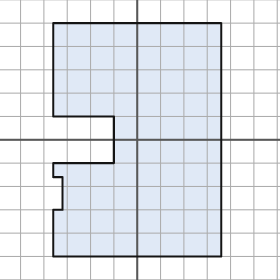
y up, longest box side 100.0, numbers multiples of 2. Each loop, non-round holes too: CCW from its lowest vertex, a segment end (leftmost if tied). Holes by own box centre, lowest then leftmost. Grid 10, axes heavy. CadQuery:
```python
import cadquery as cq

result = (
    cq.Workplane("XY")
    .moveTo(-36.0, -50.0)
    .lineTo(36.0, -50.0)
    .lineTo(36.0, 50.0)
    .lineTo(-36.0, 50.0)
    .lineTo(-36.0, 10.0)
    .lineTo(-10.0, 10.0)
    .lineTo(-10.0, -10.0)
    .lineTo(-36.0, -10.0)
    .lineTo(-36.0, -16.0)
    .lineTo(-32.0, -16.0)
    .lineTo(-32.0, -30.0)
    .lineTo(-36.0, -30.0)
    .close()
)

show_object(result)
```